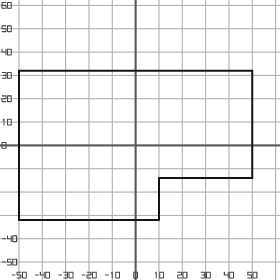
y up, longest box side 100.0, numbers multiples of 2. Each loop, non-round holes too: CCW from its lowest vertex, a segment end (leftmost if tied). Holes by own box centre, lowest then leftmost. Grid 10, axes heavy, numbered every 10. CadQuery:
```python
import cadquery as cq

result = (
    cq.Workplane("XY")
    .moveTo(-50.0, -32.0)
    .lineTo(10.0, -32.0)
    .lineTo(10.0, -14.0)
    .lineTo(50.0, -14.0)
    .lineTo(50.0, 32.0)
    .lineTo(-50.0, 32.0)
    .close()
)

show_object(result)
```